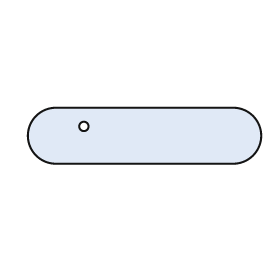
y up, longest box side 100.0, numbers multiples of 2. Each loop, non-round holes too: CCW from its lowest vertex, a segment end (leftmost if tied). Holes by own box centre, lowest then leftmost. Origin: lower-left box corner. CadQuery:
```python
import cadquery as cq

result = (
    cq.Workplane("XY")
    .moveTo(12.0, 0.0)
    .lineTo(88.0, 0.0)
    .threePointArc((100.0, 12.0), (88.0, 24.0))
    .lineTo(12.0, 24.0)
    .threePointArc((0.0, 12.0), (12.0, 0.0))
    .close()
    .moveTo(24.0, 16.0)
    .circle(2.0)
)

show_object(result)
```